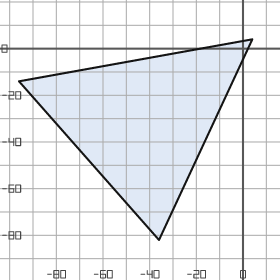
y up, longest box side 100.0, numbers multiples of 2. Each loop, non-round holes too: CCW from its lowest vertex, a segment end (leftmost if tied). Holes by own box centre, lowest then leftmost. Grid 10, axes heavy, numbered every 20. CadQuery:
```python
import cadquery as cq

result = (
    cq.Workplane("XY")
    .moveTo(-36.0, -82.0)
    .lineTo(4.0, 4.0)
    .lineTo(-96.0, -14.0)
    .close()
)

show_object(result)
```